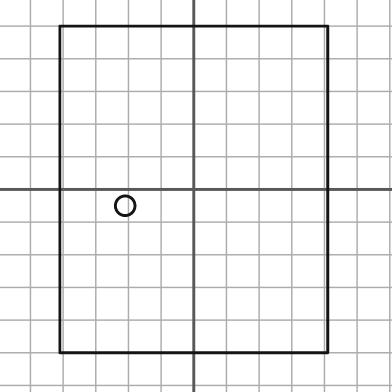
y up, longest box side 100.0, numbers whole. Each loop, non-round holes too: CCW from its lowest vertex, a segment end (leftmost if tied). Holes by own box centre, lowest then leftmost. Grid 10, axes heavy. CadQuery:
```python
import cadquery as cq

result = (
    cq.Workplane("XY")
    .moveTo(-41.0, -50.0)
    .lineTo(41.0, -50.0)
    .lineTo(41.0, 50.0)
    .lineTo(-41.0, 50.0)
    .close()
    .moveTo(-21.0, -5.0)
    .circle(3.0)
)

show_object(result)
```